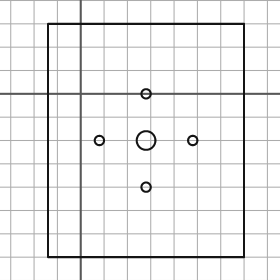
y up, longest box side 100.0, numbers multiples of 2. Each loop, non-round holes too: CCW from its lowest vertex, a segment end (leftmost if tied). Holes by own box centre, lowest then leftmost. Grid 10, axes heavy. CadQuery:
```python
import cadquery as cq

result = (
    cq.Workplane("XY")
    .moveTo(-14.0, -70.0)
    .lineTo(70.0, -70.0)
    .lineTo(70.0, 30.0)
    .lineTo(-14.0, 30.0)
    .close()
    .moveTo(28.0, -40.0)
    .circle(2.0)
    .moveTo(8.0, -20.0)
    .circle(2.0)
    .moveTo(28.0, -20.0)
    .circle(4.0)
    .moveTo(48.0, -20.0)
    .circle(2.0)
    .moveTo(28.0, 0.0)
    .circle(2.0)
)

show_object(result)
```